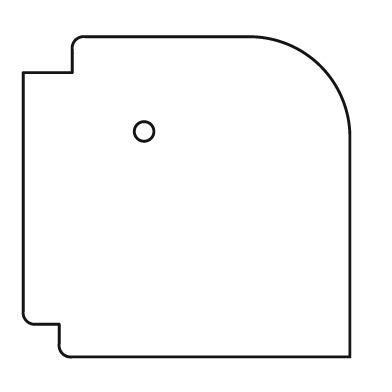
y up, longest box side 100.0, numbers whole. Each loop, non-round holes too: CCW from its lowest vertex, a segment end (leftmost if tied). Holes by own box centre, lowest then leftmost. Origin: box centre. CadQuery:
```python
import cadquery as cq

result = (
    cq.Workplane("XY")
    .moveTo(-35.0, -49.0)
    .lineTo(50.0, -49.0)
    .lineTo(50.0, 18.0)
    .threePointArc((41.0, 40.0), (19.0, 49.0))
    .lineTo(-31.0, 49.0)
    .threePointArc((-34.0, 48.0), (-35.0, 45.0))
    .lineTo(-35.0, 38.0)
    .lineTo(-50.0, 38.0)
    .lineTo(-50.0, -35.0)
    .threePointArc((-49.0, -38.0), (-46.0, -39.0))
    .lineTo(-39.0, -39.0)
    .lineTo(-39.0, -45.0)
    .threePointArc((-38.0, -48.0), (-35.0, -49.0))
    .close()
    .moveTo(-13.0, 20.0)
    .circle(3.0)
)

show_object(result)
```